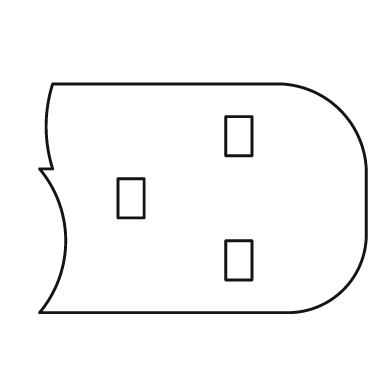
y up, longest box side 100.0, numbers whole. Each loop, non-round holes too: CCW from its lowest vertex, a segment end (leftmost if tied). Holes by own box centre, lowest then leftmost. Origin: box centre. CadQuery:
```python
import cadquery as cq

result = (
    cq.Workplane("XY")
    .moveTo(-50.0, -35.0)
    .lineTo(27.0, -35.0)
    .threePointArc((43.0, -28.0), (50.0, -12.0))
    .lineTo(50.0, 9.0)
    .threePointArc((42.0, 27.0), (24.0, 35.0))
    .lineTo(-46.0, 35.0)
    .threePointArc((-48.0, 22.0), (-46.0, 9.0))
    .lineTo(-50.0, 9.0)
    .threePointArc((-42.0, -13.0), (-50.0, -35.0))
    .close()
    .moveTo(7.0, -25.0)
    .lineTo(15.0, -25.0)
    .lineTo(15.0, -13.0)
    .lineTo(7.0, -13.0)
    .close()
    .moveTo(-26.0, -6.0)
    .lineTo(-18.0, -6.0)
    .lineTo(-18.0, 6.0)
    .lineTo(-26.0, 6.0)
    .close()
    .moveTo(7.0, 13.0)
    .lineTo(15.0, 13.0)
    .lineTo(15.0, 25.0)
    .lineTo(7.0, 25.0)
    .close()
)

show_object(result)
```